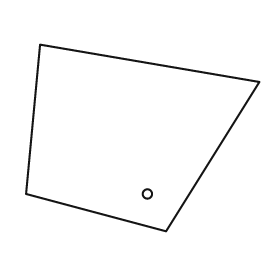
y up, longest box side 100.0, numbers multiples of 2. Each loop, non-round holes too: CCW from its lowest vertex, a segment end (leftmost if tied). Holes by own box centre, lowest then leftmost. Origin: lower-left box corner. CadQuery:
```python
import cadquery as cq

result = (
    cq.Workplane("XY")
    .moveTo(60.0, 0.0)
    .lineTo(100.0, 64.0)
    .lineTo(6.0, 80.0)
    .lineTo(0.0, 16.0)
    .close()
    .moveTo(52.0, 16.0)
    .circle(2.0)
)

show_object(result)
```